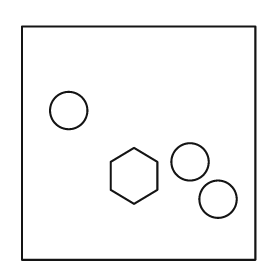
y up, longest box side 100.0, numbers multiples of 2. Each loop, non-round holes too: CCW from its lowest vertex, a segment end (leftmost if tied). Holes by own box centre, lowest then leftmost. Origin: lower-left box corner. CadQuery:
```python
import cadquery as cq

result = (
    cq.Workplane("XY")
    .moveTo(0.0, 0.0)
    .lineTo(100.0, 0.0)
    .lineTo(100.0, 100.0)
    .lineTo(0.0, 100.0)
    .close()
    .moveTo(84.0, 26.0)
    .circle(8.0)
    .moveTo(48.0, 24.0)
    .lineTo(58.0, 30.0)
    .lineTo(58.0, 42.0)
    .lineTo(48.0, 48.0)
    .lineTo(38.0, 42.0)
    .lineTo(38.0, 30.0)
    .close()
    .moveTo(72.0, 42.0)
    .circle(8.0)
    .moveTo(20.0, 64.0)
    .circle(8.0)
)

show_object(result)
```